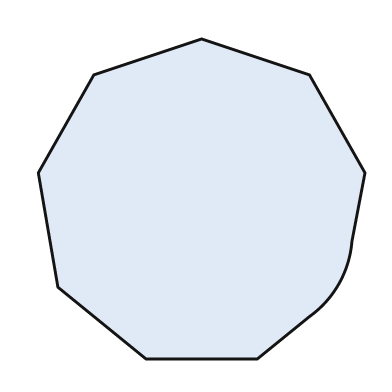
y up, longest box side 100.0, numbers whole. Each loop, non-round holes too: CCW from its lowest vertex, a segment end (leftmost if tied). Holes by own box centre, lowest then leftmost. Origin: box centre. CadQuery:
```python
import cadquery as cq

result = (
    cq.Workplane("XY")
    .moveTo(-17.0, -49.0)
    .lineTo(17.0, -49.0)
    .lineTo(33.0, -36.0)
    .threePointArc((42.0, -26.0), (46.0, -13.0))
    .lineTo(50.0, 8.0)
    .lineTo(33.0, 38.0)
    .lineTo(0.0, 49.0)
    .lineTo(-33.0, 38.0)
    .lineTo(-50.0, 8.0)
    .lineTo(-44.0, -27.0)
    .close()
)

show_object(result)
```